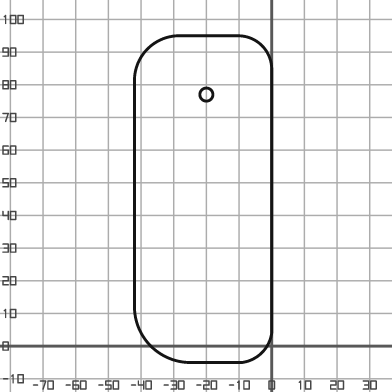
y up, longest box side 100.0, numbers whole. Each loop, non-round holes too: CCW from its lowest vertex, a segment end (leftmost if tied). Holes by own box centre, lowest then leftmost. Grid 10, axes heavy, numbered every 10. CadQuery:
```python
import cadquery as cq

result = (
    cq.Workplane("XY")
    .moveTo(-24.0, -5.0)
    .lineTo(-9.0, -5.0)
    .threePointArc((-3.0, -2.0), (0.0, 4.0))
    .lineTo(0.0, 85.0)
    .threePointArc((-3.0, 92.0), (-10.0, 95.0))
    .lineTo(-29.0, 95.0)
    .threePointArc((-38.0, 91.0), (-42.0, 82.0))
    .lineTo(-42.0, 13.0)
    .threePointArc((-37.0, 0.0), (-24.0, -5.0))
    .close()
    .moveTo(-20.0, 77.0)
    .circle(2.0)
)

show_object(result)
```